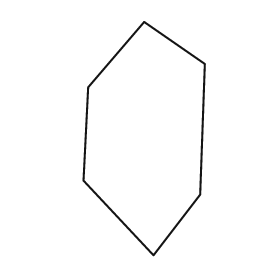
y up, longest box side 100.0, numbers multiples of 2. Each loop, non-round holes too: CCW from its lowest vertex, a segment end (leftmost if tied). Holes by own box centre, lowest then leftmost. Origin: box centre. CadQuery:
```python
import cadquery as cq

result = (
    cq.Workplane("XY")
    .moveTo(4.0, -50.0)
    .lineTo(24.0, -24.0)
    .lineTo(26.0, 32.0)
    .lineTo(0.0, 50.0)
    .lineTo(-24.0, 22.0)
    .lineTo(-26.0, -18.0)
    .close()
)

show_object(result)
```